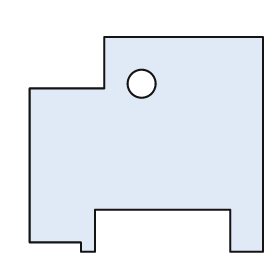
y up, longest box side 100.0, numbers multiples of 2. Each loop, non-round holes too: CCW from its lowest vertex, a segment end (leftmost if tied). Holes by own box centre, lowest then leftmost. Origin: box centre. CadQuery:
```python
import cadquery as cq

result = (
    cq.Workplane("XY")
    .moveTo(-28.0, -46.0)
    .lineTo(-22.0, -46.0)
    .lineTo(-22.0, -28.0)
    .lineTo(36.0, -28.0)
    .lineTo(36.0, -46.0)
    .lineTo(50.0, -46.0)
    .lineTo(50.0, 46.0)
    .lineTo(-18.0, 46.0)
    .lineTo(-18.0, 24.0)
    .lineTo(-50.0, 24.0)
    .lineTo(-50.0, -42.0)
    .lineTo(-28.0, -42.0)
    .close()
    .moveTo(-2.0, 26.0)
    .circle(6.0)
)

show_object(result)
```